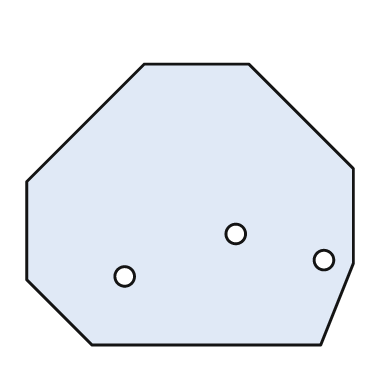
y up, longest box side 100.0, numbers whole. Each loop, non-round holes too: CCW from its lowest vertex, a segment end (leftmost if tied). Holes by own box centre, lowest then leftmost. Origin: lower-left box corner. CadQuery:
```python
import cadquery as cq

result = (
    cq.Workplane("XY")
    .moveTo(20.0, 0.0)
    .lineTo(90.0, 0.0)
    .lineTo(100.0, 25.0)
    .lineTo(100.0, 54.0)
    .lineTo(68.0, 86.0)
    .lineTo(36.0, 86.0)
    .lineTo(0.0, 50.0)
    .lineTo(0.0, 20.0)
    .close()
    .moveTo(30.0, 21.0)
    .circle(3.0)
    .moveTo(91.0, 26.0)
    .circle(3.0)
    .moveTo(64.0, 34.0)
    .circle(3.0)
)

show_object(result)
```